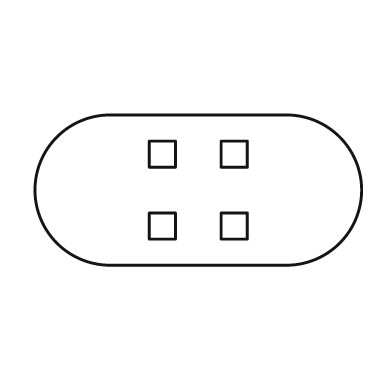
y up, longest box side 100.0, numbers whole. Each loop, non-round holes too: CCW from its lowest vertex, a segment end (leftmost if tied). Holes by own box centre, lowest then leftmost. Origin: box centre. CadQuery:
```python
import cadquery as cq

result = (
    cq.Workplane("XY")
    .moveTo(-27.0, -23.0)
    .lineTo(27.0, -23.0)
    .threePointArc((50.0, 0.0), (27.0, 23.0))
    .lineTo(-27.0, 23.0)
    .threePointArc((-50.0, 0.0), (-27.0, -23.0))
    .close()
    .moveTo(-15.0, -15.0)
    .lineTo(-7.0, -15.0)
    .lineTo(-7.0, -7.0)
    .lineTo(-15.0, -7.0)
    .close()
    .moveTo(7.0, -15.0)
    .lineTo(15.0, -15.0)
    .lineTo(15.0, -7.0)
    .lineTo(7.0, -7.0)
    .close()
    .moveTo(-15.0, 7.0)
    .lineTo(-7.0, 7.0)
    .lineTo(-7.0, 15.0)
    .lineTo(-15.0, 15.0)
    .close()
    .moveTo(7.0, 7.0)
    .lineTo(15.0, 7.0)
    .lineTo(15.0, 15.0)
    .lineTo(7.0, 15.0)
    .close()
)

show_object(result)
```